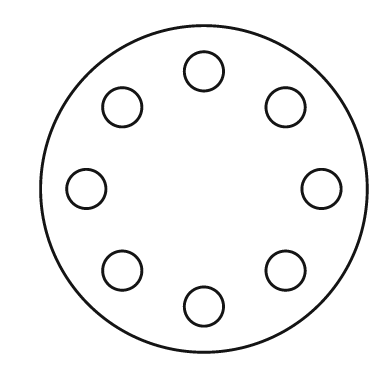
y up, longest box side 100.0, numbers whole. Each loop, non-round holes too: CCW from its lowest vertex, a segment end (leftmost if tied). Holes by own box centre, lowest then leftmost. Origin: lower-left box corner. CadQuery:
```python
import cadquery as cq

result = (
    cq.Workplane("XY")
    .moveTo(50.0, 50.0)
    .circle(50.0)
    .moveTo(50.0, 14.0)
    .circle(6.0)
    .moveTo(25.0, 25.0)
    .circle(6.0)
    .moveTo(75.0, 25.0)
    .circle(6.0)
    .moveTo(14.0, 50.0)
    .circle(6.0)
    .moveTo(86.0, 50.0)
    .circle(6.0)
    .moveTo(25.0, 75.0)
    .circle(6.0)
    .moveTo(75.0, 75.0)
    .circle(6.0)
    .moveTo(50.0, 86.0)
    .circle(6.0)
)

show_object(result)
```